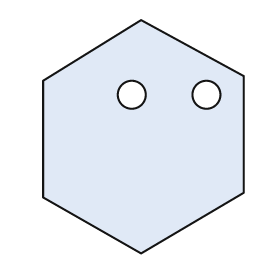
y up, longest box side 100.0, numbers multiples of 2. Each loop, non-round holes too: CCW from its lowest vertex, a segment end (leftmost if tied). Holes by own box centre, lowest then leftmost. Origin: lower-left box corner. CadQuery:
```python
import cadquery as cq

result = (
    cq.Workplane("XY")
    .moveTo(42.0, 0.0)
    .lineTo(86.0, 26.0)
    .lineTo(86.0, 76.0)
    .lineTo(42.0, 100.0)
    .lineTo(0.0, 74.0)
    .lineTo(0.0, 24.0)
    .close()
    .moveTo(38.0, 68.0)
    .circle(6.0)
    .moveTo(70.0, 68.0)
    .circle(6.0)
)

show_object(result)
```